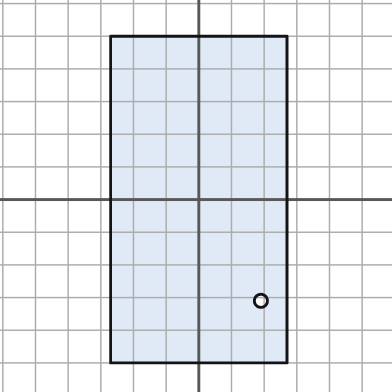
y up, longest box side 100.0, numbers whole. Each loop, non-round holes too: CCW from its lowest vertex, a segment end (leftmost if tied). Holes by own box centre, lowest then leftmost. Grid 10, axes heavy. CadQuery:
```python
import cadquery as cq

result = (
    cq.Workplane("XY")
    .moveTo(-27.0, -50.0)
    .lineTo(27.0, -50.0)
    .lineTo(27.0, 50.0)
    .lineTo(-27.0, 50.0)
    .close()
    .moveTo(19.0, -31.0)
    .circle(2.0)
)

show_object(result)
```